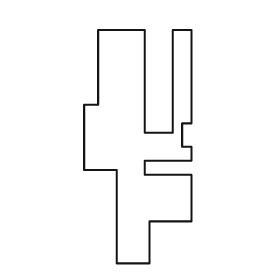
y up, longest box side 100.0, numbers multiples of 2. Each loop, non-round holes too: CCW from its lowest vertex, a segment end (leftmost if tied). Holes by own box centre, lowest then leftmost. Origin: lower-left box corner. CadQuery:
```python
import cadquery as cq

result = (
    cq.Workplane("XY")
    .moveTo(14.0, 0.0)
    .lineTo(28.0, 0.0)
    .lineTo(28.0, 18.0)
    .lineTo(46.0, 18.0)
    .lineTo(46.0, 38.0)
    .lineTo(26.0, 38.0)
    .lineTo(26.0, 44.0)
    .lineTo(46.0, 44.0)
    .lineTo(46.0, 50.0)
    .lineTo(42.0, 50.0)
    .lineTo(42.0, 60.0)
    .lineTo(46.0, 60.0)
    .lineTo(46.0, 100.0)
    .lineTo(38.0, 100.0)
    .lineTo(38.0, 56.0)
    .lineTo(26.0, 56.0)
    .lineTo(26.0, 100.0)
    .lineTo(6.0, 100.0)
    .lineTo(6.0, 68.0)
    .lineTo(0.0, 68.0)
    .lineTo(0.0, 40.0)
    .lineTo(14.0, 40.0)
    .close()
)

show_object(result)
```